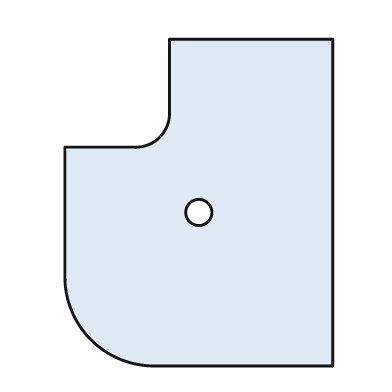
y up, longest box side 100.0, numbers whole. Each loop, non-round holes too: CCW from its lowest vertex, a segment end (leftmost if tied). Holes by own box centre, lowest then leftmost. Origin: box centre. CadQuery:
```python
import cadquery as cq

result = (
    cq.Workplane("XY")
    .moveTo(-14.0, -50.0)
    .lineTo(41.0, -50.0)
    .lineTo(41.0, 50.0)
    .lineTo(-9.0, 50.0)
    .lineTo(-9.0, 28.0)
    .threePointArc((-12.0, 20.0), (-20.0, 17.0))
    .lineTo(-41.0, 17.0)
    .lineTo(-41.0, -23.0)
    .threePointArc((-33.0, -42.0), (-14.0, -50.0))
    .close()
    .moveTo(0.0, -3.0)
    .circle(4.0)
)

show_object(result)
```